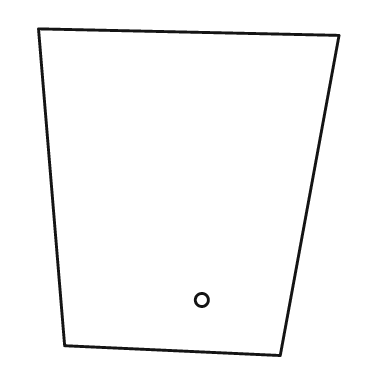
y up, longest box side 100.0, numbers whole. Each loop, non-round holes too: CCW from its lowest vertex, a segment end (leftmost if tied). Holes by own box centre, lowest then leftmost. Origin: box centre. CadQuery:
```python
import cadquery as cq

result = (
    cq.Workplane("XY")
    .moveTo(28.0, -50.0)
    .lineTo(46.0, 48.0)
    .lineTo(-46.0, 50.0)
    .lineTo(-38.0, -47.0)
    .close()
    .moveTo(4.0, -33.0)
    .circle(2.0)
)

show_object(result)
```